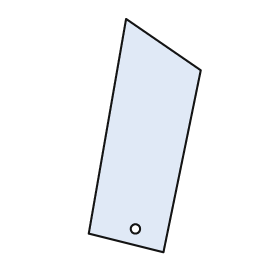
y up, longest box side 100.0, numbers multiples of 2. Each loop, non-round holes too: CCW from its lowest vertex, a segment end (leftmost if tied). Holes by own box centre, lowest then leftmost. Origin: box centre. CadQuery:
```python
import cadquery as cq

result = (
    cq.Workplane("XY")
    .moveTo(8.0, -50.0)
    .lineTo(24.0, 28.0)
    .lineTo(-8.0, 50.0)
    .lineTo(-24.0, -42.0)
    .close()
    .moveTo(-4.0, -40.0)
    .circle(2.0)
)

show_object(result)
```